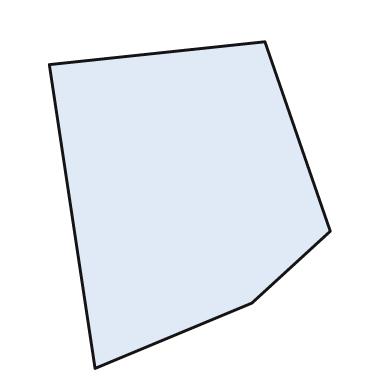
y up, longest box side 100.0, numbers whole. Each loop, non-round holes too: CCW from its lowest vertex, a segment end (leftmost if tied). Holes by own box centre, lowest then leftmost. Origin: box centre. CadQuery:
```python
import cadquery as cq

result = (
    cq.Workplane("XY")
    .moveTo(-29.0, -50.0)
    .lineTo(19.0, -30.0)
    .lineTo(43.0, -8.0)
    .lineTo(23.0, 50.0)
    .lineTo(-43.0, 43.0)
    .close()
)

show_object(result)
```